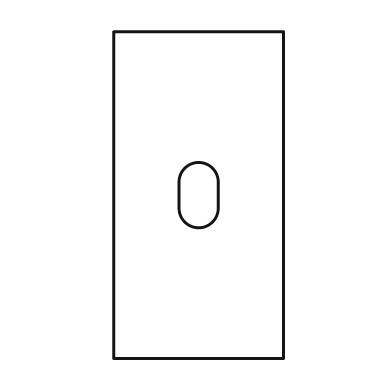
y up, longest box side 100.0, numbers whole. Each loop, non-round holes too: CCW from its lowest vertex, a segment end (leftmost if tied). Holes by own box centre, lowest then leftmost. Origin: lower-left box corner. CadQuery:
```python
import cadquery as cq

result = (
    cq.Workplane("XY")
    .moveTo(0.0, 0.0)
    .lineTo(52.0, 0.0)
    .lineTo(52.0, 100.0)
    .lineTo(0.0, 100.0)
    .close()
    .moveTo(20.0, 46.0)
    .threePointArc((26.0, 40.0), (32.0, 46.0))
    .lineTo(32.0, 54.0)
    .threePointArc((26.0, 60.0), (20.0, 54.0))
    .close()
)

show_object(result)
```